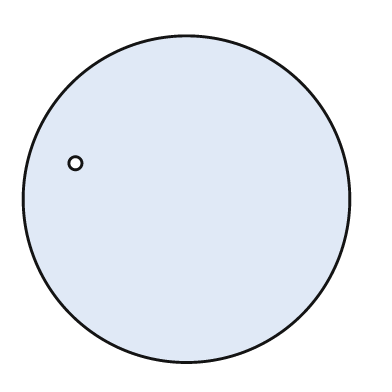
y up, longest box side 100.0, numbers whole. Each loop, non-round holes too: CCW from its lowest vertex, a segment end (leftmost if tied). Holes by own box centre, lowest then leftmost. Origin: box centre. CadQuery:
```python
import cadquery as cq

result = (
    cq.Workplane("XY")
    .moveTo(0.0, 0.0)
    .circle(50.0)
    .moveTo(-34.0, 11.0)
    .circle(2.0)
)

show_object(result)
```